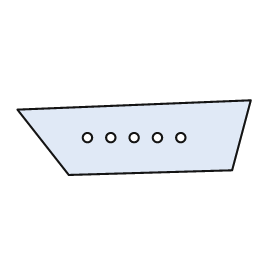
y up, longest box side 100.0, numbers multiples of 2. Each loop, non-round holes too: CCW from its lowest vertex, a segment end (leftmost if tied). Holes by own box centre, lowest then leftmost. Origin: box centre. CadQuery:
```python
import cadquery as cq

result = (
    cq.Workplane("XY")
    .moveTo(-28.0, -16.0)
    .lineTo(42.0, -14.0)
    .lineTo(50.0, 16.0)
    .lineTo(-50.0, 12.0)
    .close()
    .moveTo(-20.0, 0.0)
    .circle(2.0)
    .moveTo(-10.0, 0.0)
    .circle(2.0)
    .moveTo(0.0, 0.0)
    .circle(2.0)
    .moveTo(10.0, 0.0)
    .circle(2.0)
    .moveTo(20.0, 0.0)
    .circle(2.0)
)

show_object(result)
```